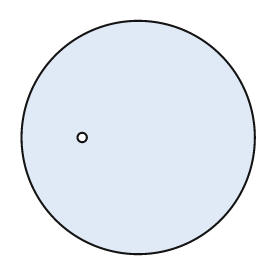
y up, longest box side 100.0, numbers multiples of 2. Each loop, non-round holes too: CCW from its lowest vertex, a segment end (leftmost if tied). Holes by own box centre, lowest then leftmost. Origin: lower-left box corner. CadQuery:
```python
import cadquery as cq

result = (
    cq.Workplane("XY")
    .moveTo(50.0, 50.0)
    .circle(50.0)
    .moveTo(26.0, 50.0)
    .circle(2.0)
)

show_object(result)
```